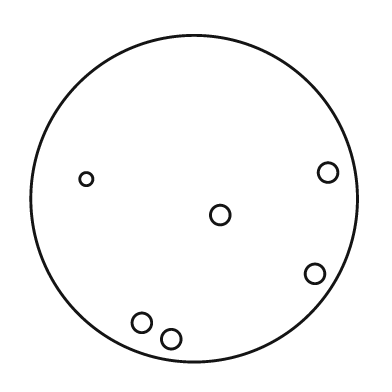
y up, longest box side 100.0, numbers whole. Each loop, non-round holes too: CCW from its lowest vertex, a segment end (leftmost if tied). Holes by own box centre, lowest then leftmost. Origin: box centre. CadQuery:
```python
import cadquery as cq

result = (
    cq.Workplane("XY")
    .moveTo(0.0, 0.0)
    .circle(50.0)
    .moveTo(-7.0, -43.0)
    .circle(3.0)
    .moveTo(-16.0, -38.0)
    .circle(3.0)
    .moveTo(37.0, -23.0)
    .circle(3.0)
    .moveTo(8.0, -5.0)
    .circle(3.0)
    .moveTo(-33.0, 6.0)
    .circle(2.0)
    .moveTo(41.0, 8.0)
    .circle(3.0)
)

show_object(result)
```